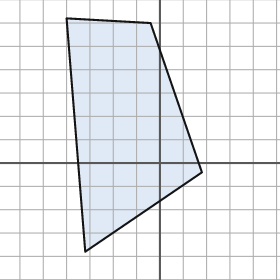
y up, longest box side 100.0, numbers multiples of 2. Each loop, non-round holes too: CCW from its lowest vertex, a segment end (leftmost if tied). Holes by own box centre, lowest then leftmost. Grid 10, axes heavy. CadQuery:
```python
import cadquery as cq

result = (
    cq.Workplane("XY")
    .moveTo(-32.0, -38.0)
    .lineTo(18.0, -4.0)
    .lineTo(-4.0, 60.0)
    .lineTo(-40.0, 62.0)
    .close()
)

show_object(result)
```